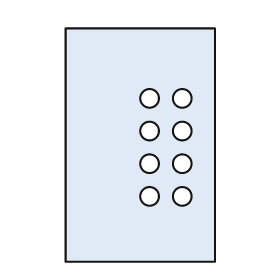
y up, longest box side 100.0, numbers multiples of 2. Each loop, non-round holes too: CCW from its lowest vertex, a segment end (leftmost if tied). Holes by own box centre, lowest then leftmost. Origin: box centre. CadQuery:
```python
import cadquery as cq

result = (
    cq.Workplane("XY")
    .moveTo(-32.0, -50.0)
    .lineTo(32.0, -50.0)
    .lineTo(32.0, 50.0)
    .lineTo(-32.0, 50.0)
    .close()
    .moveTo(4.0, -22.0)
    .circle(4.0)
    .moveTo(18.0, -22.0)
    .circle(4.0)
    .moveTo(4.0, -8.0)
    .circle(4.0)
    .moveTo(18.0, -8.0)
    .circle(4.0)
    .moveTo(4.0, 6.0)
    .circle(4.0)
    .moveTo(18.0, 6.0)
    .circle(4.0)
    .moveTo(4.0, 20.0)
    .circle(4.0)
    .moveTo(18.0, 20.0)
    .circle(4.0)
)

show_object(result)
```